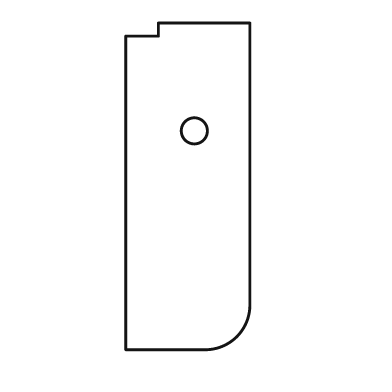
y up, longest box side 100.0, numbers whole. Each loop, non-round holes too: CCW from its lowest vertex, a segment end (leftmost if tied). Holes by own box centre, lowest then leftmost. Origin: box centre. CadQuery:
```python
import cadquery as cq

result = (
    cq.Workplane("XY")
    .moveTo(-19.0, -50.0)
    .lineTo(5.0, -50.0)
    .threePointArc((15.0, -46.0), (19.0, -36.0))
    .lineTo(19.0, 50.0)
    .lineTo(-9.0, 50.0)
    .lineTo(-9.0, 46.0)
    .lineTo(-19.0, 46.0)
    .close()
    .moveTo(2.0, 17.0)
    .circle(4.0)
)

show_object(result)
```